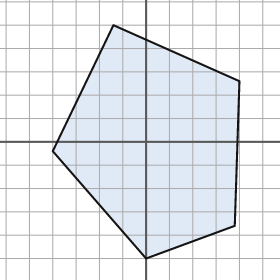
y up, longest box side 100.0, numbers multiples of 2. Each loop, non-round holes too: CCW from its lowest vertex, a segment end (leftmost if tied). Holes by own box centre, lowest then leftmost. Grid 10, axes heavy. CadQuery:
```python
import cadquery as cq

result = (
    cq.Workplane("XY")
    .moveTo(0.0, -50.0)
    .lineTo(38.0, -36.0)
    .lineTo(40.0, 26.0)
    .lineTo(-14.0, 50.0)
    .lineTo(-40.0, -4.0)
    .close()
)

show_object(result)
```